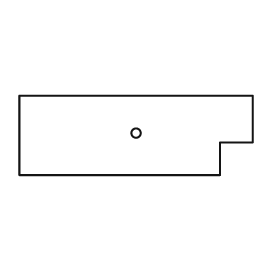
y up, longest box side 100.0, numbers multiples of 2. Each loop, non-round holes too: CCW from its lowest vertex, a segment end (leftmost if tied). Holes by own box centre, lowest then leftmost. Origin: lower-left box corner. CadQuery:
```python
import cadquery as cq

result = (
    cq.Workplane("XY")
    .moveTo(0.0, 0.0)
    .lineTo(86.0, 0.0)
    .lineTo(86.0, 14.0)
    .lineTo(100.0, 14.0)
    .lineTo(100.0, 34.0)
    .lineTo(0.0, 34.0)
    .close()
    .moveTo(50.0, 18.0)
    .circle(2.0)
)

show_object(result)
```